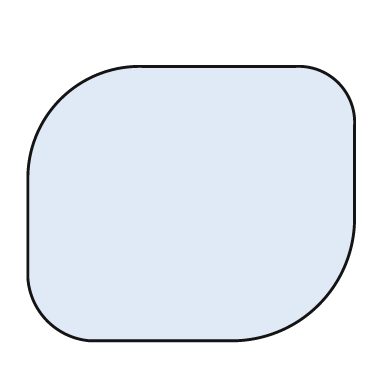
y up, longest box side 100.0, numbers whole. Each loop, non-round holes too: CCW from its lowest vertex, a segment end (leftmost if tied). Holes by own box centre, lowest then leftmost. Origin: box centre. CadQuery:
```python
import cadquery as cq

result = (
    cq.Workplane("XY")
    .moveTo(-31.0, -42.0)
    .lineTo(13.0, -42.0)
    .threePointArc((39.0, -31.0), (50.0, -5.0))
    .lineTo(50.0, 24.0)
    .threePointArc((45.0, 37.0), (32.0, 42.0))
    .lineTo(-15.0, 42.0)
    .threePointArc((-40.0, 32.0), (-50.0, 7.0))
    .lineTo(-50.0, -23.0)
    .threePointArc((-44.0, -36.0), (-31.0, -42.0))
    .close()
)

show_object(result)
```